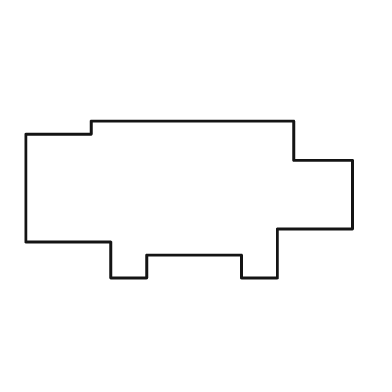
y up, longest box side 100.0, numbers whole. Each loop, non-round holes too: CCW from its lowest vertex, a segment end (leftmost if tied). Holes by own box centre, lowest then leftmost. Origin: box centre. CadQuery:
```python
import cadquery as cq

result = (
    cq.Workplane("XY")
    .moveTo(-24.0, -24.0)
    .lineTo(-13.0, -24.0)
    .lineTo(-13.0, -17.0)
    .lineTo(16.0, -17.0)
    .lineTo(16.0, -24.0)
    .lineTo(27.0, -24.0)
    .lineTo(27.0, -9.0)
    .lineTo(50.0, -9.0)
    .lineTo(50.0, 12.0)
    .lineTo(32.0, 12.0)
    .lineTo(32.0, 24.0)
    .lineTo(-30.0, 24.0)
    .lineTo(-30.0, 20.0)
    .lineTo(-50.0, 20.0)
    .lineTo(-50.0, -13.0)
    .lineTo(-24.0, -13.0)
    .close()
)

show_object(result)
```